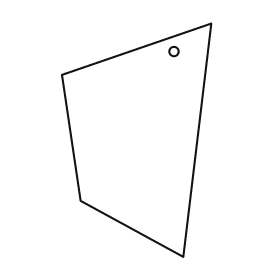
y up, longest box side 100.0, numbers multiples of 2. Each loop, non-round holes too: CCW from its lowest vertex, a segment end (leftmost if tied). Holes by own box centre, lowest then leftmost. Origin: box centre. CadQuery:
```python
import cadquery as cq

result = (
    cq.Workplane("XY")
    .moveTo(20.0, -50.0)
    .lineTo(32.0, 50.0)
    .lineTo(-32.0, 28.0)
    .lineTo(-24.0, -26.0)
    .close()
    .moveTo(16.0, 38.0)
    .circle(2.0)
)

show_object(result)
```